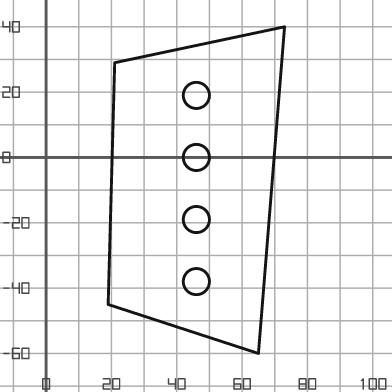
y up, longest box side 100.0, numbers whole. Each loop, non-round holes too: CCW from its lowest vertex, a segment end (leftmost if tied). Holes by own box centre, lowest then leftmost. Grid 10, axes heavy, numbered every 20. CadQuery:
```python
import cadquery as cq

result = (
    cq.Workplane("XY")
    .moveTo(65.0, -60.0)
    .lineTo(73.0, 40.0)
    .lineTo(21.0, 29.0)
    .lineTo(19.0, -45.0)
    .close()
    .moveTo(46.0, -38.0)
    .circle(4.0)
    .moveTo(46.0, -19.0)
    .circle(4.0)
    .moveTo(46.0, 0.0)
    .circle(4.0)
    .moveTo(46.0, 19.0)
    .circle(4.0)
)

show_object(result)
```